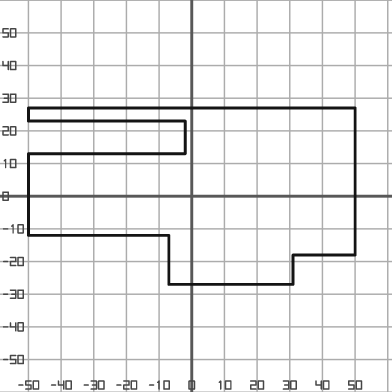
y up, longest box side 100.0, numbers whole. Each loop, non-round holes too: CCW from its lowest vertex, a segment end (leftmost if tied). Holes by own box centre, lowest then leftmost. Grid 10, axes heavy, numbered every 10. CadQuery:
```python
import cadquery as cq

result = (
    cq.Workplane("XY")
    .moveTo(-7.0, -27.0)
    .lineTo(31.0, -27.0)
    .lineTo(31.0, -18.0)
    .lineTo(50.0, -18.0)
    .lineTo(50.0, 27.0)
    .lineTo(-50.0, 27.0)
    .lineTo(-50.0, 23.0)
    .lineTo(-2.0, 23.0)
    .lineTo(-2.0, 13.0)
    .lineTo(-50.0, 13.0)
    .lineTo(-50.0, -12.0)
    .lineTo(-7.0, -12.0)
    .close()
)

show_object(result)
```